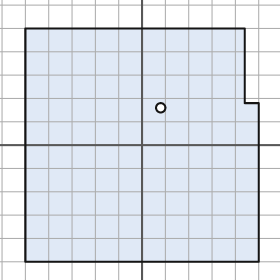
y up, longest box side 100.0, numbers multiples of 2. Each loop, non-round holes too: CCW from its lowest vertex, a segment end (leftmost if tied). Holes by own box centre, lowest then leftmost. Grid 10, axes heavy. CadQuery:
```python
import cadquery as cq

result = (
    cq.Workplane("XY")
    .moveTo(-50.0, -50.0)
    .lineTo(50.0, -50.0)
    .lineTo(50.0, 18.0)
    .lineTo(44.0, 18.0)
    .lineTo(44.0, 50.0)
    .lineTo(-50.0, 50.0)
    .close()
    .moveTo(8.0, 16.0)
    .circle(2.0)
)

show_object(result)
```